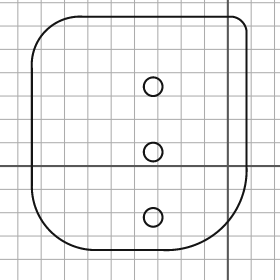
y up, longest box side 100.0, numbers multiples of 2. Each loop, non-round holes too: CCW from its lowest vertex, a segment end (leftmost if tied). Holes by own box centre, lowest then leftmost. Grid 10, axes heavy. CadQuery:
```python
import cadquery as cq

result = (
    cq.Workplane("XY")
    .moveTo(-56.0, -36.0)
    .lineTo(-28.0, -36.0)
    .threePointArc((-2.0, -26.0), (8.0, 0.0))
    .lineTo(8.0, 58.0)
    .threePointArc((6.0, 62.0), (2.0, 64.0))
    .lineTo(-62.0, 64.0)
    .threePointArc((-78.0, 58.0), (-84.0, 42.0))
    .lineTo(-84.0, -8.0)
    .threePointArc((-76.0, -28.0), (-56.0, -36.0))
    .close()
    .moveTo(-32.0, -22.0)
    .circle(4.0)
    .moveTo(-32.0, 6.0)
    .circle(4.0)
    .moveTo(-32.0, 34.0)
    .circle(4.0)
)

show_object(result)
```